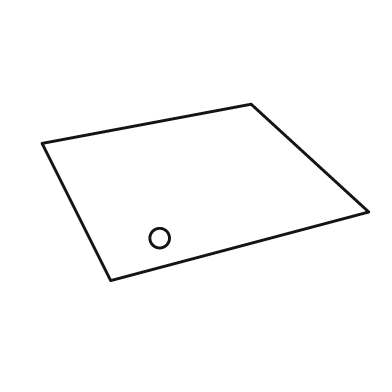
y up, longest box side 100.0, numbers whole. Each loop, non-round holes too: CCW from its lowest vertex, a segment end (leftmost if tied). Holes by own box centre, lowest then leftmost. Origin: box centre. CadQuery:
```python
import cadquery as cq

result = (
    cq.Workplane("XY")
    .moveTo(-29.0, -27.0)
    .lineTo(50.0, -6.0)
    .lineTo(14.0, 27.0)
    .lineTo(-50.0, 15.0)
    .close()
    .moveTo(-14.0, -14.0)
    .circle(3.0)
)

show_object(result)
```